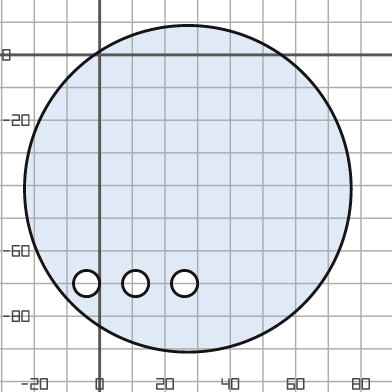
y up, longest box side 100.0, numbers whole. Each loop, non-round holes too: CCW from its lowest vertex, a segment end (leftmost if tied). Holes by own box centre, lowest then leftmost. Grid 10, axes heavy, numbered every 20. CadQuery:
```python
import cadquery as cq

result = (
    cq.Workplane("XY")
    .moveTo(27.0, -41.0)
    .circle(50.0)
    .moveTo(-4.0, -70.0)
    .circle(4.0)
    .moveTo(11.0, -70.0)
    .circle(4.0)
    .moveTo(26.0, -70.0)
    .circle(4.0)
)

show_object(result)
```